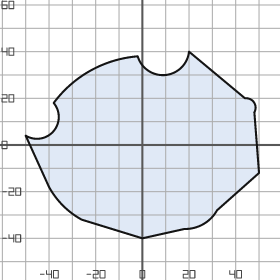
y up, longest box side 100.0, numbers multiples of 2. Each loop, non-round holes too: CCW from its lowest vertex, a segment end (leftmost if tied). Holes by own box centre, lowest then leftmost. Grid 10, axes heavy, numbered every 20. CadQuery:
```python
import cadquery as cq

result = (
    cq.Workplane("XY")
    .moveTo(0.0, -40.0)
    .lineTo(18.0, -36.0)
    .threePointArc((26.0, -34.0), (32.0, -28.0))
    .lineTo(50.0, -12.0)
    .lineTo(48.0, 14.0)
    .threePointArc((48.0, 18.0), (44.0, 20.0))
    .lineTo(20.0, 40.0)
    .threePointArc((10.0, 30.0), (-2.0, 38.0))
    .threePointArc((-22.0, 32.0), (-38.0, 18.0))
    .threePointArc((-38.0, 6.0), (-50.0, 4.0))
    .lineTo(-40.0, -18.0)
    .threePointArc((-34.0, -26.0), (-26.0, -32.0))
    .close()
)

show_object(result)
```